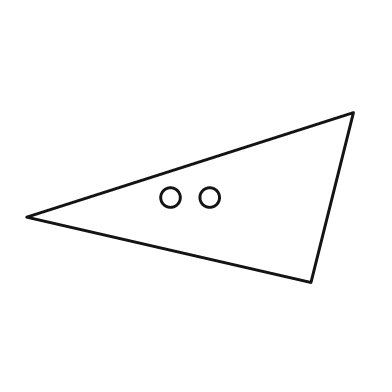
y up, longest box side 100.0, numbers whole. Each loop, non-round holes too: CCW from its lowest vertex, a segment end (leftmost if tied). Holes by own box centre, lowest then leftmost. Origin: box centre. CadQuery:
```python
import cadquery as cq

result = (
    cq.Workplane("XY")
    .moveTo(37.0, -26.0)
    .lineTo(50.0, 26.0)
    .lineTo(-50.0, -6.0)
    .close()
    .moveTo(-6.0, 0.0)
    .circle(3.0)
    .moveTo(6.0, 0.0)
    .circle(3.0)
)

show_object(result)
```